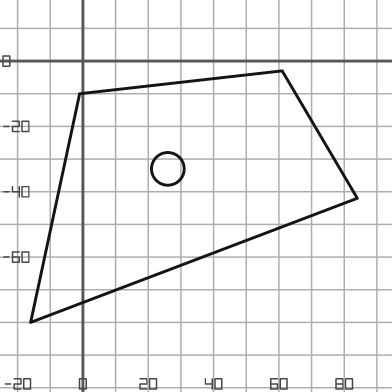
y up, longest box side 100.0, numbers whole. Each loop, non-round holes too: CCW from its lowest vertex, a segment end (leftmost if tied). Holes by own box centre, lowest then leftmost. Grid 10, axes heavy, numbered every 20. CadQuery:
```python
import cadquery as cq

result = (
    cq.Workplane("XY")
    .moveTo(-16.0, -80.0)
    .lineTo(84.0, -42.0)
    .lineTo(61.0, -3.0)
    .lineTo(-1.0, -10.0)
    .close()
    .moveTo(26.0, -33.0)
    .circle(5.0)
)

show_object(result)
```